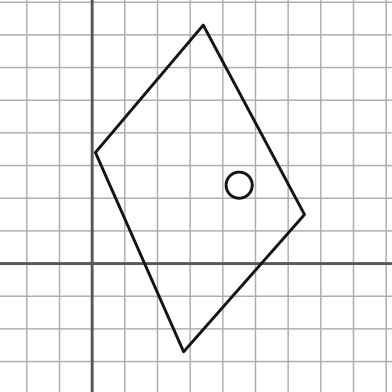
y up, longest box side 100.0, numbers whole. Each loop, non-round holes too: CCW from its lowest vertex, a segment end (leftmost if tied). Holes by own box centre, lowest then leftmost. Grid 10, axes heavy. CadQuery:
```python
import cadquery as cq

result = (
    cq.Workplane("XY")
    .moveTo(28.0, -27.0)
    .lineTo(65.0, 15.0)
    .lineTo(34.0, 73.0)
    .lineTo(1.0, 34.0)
    .close()
    .moveTo(45.0, 24.0)
    .circle(4.0)
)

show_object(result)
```